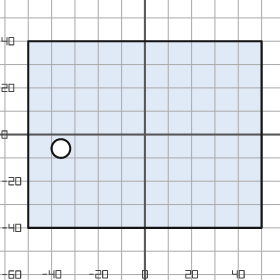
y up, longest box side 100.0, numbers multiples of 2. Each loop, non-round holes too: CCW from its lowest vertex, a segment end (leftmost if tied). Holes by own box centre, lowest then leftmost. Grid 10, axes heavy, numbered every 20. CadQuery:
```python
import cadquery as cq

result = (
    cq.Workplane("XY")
    .moveTo(-50.0, -40.0)
    .lineTo(50.0, -40.0)
    .lineTo(50.0, 40.0)
    .lineTo(-50.0, 40.0)
    .close()
    .moveTo(-36.0, -6.0)
    .circle(4.0)
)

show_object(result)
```